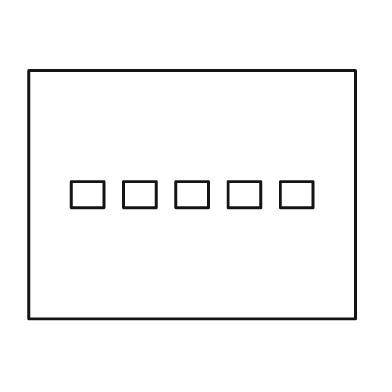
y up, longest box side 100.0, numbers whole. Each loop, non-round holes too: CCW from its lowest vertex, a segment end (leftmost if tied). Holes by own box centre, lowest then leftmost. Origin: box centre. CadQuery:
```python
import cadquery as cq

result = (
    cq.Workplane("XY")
    .moveTo(-50.0, -38.0)
    .lineTo(50.0, -38.0)
    .lineTo(50.0, 38.0)
    .lineTo(-50.0, 38.0)
    .close()
    .moveTo(-37.0, -4.0)
    .lineTo(-27.0, -4.0)
    .lineTo(-27.0, 4.0)
    .lineTo(-37.0, 4.0)
    .close()
    .moveTo(-21.0, -4.0)
    .lineTo(-11.0, -4.0)
    .lineTo(-11.0, 4.0)
    .lineTo(-21.0, 4.0)
    .close()
    .moveTo(-5.0, -4.0)
    .lineTo(5.0, -4.0)
    .lineTo(5.0, 4.0)
    .lineTo(-5.0, 4.0)
    .close()
    .moveTo(11.0, -4.0)
    .lineTo(21.0, -4.0)
    .lineTo(21.0, 4.0)
    .lineTo(11.0, 4.0)
    .close()
    .moveTo(27.0, -4.0)
    .lineTo(37.0, -4.0)
    .lineTo(37.0, 4.0)
    .lineTo(27.0, 4.0)
    .close()
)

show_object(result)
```